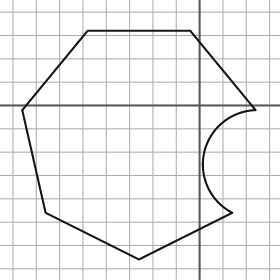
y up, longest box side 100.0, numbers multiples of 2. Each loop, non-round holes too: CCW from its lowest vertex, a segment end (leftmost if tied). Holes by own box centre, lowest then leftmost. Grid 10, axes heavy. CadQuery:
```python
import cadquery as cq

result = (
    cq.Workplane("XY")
    .moveTo(-26.0, -66.0)
    .lineTo(14.0, -46.0)
    .threePointArc((2.0, -20.0), (24.0, -2.0))
    .lineTo(-4.0, 32.0)
    .lineTo(-48.0, 32.0)
    .lineTo(-76.0, -2.0)
    .lineTo(-66.0, -46.0)
    .close()
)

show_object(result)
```